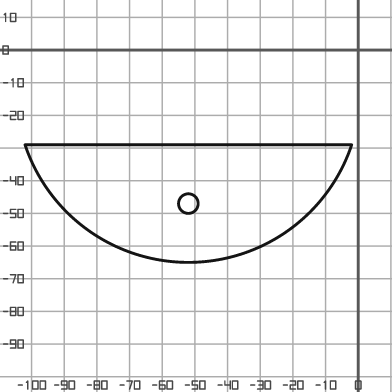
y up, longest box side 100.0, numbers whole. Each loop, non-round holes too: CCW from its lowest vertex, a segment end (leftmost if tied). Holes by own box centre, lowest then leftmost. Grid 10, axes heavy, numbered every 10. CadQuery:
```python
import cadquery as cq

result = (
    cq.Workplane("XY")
    .moveTo(-102.0, -29.0)
    .threePointArc((-52.0, -65.0), (-2.0, -29.0))
    .close()
    .moveTo(-52.0, -47.0)
    .circle(3.0)
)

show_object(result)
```